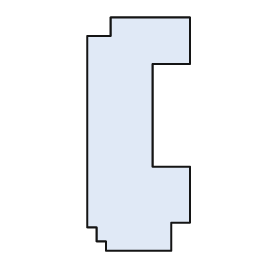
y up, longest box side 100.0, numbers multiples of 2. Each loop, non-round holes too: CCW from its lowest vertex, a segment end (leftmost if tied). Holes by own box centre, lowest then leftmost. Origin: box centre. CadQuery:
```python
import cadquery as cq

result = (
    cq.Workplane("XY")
    .moveTo(-14.0, -50.0)
    .lineTo(14.0, -50.0)
    .lineTo(14.0, -38.0)
    .lineTo(22.0, -38.0)
    .lineTo(22.0, -14.0)
    .lineTo(6.0, -14.0)
    .lineTo(6.0, 30.0)
    .lineTo(22.0, 30.0)
    .lineTo(22.0, 50.0)
    .lineTo(-12.0, 50.0)
    .lineTo(-12.0, 42.0)
    .lineTo(-22.0, 42.0)
    .lineTo(-22.0, -40.0)
    .lineTo(-18.0, -40.0)
    .lineTo(-18.0, -46.0)
    .lineTo(-14.0, -46.0)
    .close()
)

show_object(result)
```